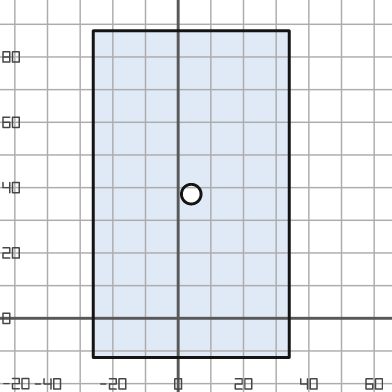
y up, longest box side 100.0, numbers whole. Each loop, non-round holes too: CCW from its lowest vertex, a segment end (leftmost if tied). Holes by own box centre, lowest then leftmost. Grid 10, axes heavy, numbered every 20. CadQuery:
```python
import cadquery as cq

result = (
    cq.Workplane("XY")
    .moveTo(-26.0, -12.0)
    .lineTo(34.0, -12.0)
    .lineTo(34.0, 88.0)
    .lineTo(-26.0, 88.0)
    .close()
    .moveTo(4.0, 38.0)
    .circle(3.0)
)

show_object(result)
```